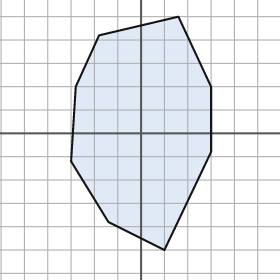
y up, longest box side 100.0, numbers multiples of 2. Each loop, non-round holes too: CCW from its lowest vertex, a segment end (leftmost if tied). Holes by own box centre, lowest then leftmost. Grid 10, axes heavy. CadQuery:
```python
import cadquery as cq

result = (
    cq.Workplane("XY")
    .moveTo(10.0, -50.0)
    .lineTo(30.0, -8.0)
    .lineTo(30.0, 20.0)
    .lineTo(16.0, 50.0)
    .lineTo(-18.0, 42.0)
    .lineTo(-28.0, 20.0)
    .lineTo(-30.0, -12.0)
    .lineTo(-14.0, -38.0)
    .close()
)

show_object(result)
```